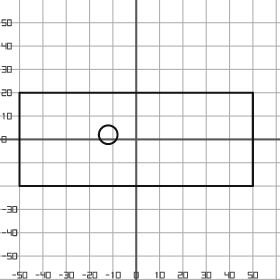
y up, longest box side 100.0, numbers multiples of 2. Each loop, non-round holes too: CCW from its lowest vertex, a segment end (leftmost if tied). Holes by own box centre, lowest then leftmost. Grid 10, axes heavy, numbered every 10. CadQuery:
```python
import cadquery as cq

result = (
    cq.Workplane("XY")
    .moveTo(-50.0, -20.0)
    .lineTo(50.0, -20.0)
    .lineTo(50.0, 20.0)
    .lineTo(-50.0, 20.0)
    .close()
    .moveTo(-12.0, 2.0)
    .circle(4.0)
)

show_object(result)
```